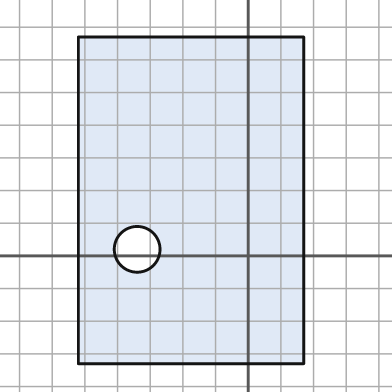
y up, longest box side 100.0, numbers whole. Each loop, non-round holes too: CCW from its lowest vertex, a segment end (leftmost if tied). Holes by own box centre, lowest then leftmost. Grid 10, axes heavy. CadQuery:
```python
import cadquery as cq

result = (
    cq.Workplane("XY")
    .moveTo(-52.0, -33.0)
    .lineTo(17.0, -33.0)
    .lineTo(17.0, 67.0)
    .lineTo(-52.0, 67.0)
    .close()
    .moveTo(-34.0, 2.0)
    .circle(7.0)
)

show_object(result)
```